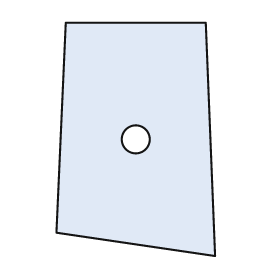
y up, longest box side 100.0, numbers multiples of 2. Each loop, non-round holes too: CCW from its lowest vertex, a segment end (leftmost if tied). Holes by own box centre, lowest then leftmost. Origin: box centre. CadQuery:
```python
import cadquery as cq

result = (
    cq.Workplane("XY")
    .moveTo(34.0, -50.0)
    .lineTo(30.0, 50.0)
    .lineTo(-30.0, 50.0)
    .lineTo(-34.0, -40.0)
    .close()
    .moveTo(0.0, 0.0)
    .circle(6.0)
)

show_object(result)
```